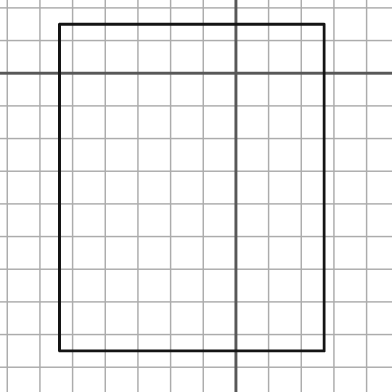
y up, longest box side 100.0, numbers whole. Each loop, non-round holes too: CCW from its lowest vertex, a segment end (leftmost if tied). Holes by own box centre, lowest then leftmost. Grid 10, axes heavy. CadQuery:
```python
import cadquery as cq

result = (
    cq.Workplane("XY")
    .moveTo(-54.0, -85.0)
    .lineTo(27.0, -85.0)
    .lineTo(27.0, 15.0)
    .lineTo(-54.0, 15.0)
    .close()
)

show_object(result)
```